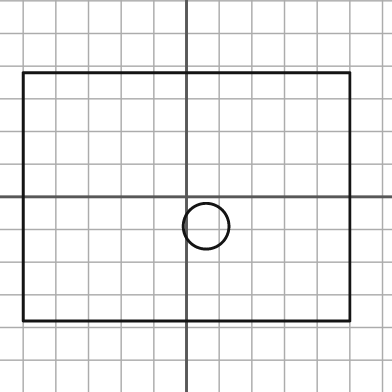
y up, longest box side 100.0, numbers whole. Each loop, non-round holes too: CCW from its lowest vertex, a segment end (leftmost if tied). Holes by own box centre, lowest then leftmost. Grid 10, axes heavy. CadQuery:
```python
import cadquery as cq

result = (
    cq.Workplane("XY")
    .moveTo(-50.0, -38.0)
    .lineTo(50.0, -38.0)
    .lineTo(50.0, 38.0)
    .lineTo(-50.0, 38.0)
    .close()
    .moveTo(6.0, -9.0)
    .circle(7.0)
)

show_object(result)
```